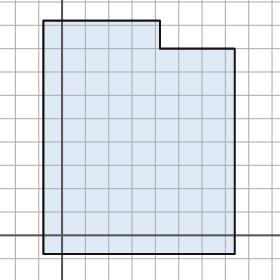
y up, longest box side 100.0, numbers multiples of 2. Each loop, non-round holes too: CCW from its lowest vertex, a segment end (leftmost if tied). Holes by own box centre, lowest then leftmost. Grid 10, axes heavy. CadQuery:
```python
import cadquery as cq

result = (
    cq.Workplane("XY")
    .moveTo(-8.0, -8.0)
    .lineTo(74.0, -8.0)
    .lineTo(74.0, 80.0)
    .lineTo(42.0, 80.0)
    .lineTo(42.0, 92.0)
    .lineTo(-8.0, 92.0)
    .close()
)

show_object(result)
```